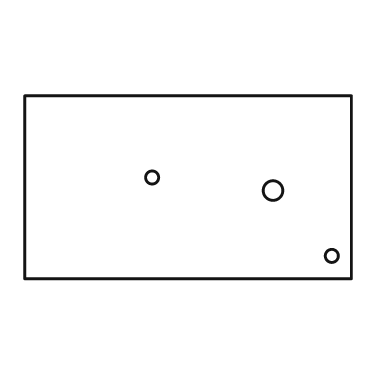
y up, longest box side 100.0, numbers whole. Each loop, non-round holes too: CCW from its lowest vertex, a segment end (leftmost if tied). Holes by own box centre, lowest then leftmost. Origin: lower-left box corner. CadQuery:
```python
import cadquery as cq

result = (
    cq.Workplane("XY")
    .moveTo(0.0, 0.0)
    .lineTo(100.0, 0.0)
    .lineTo(100.0, 56.0)
    .lineTo(0.0, 56.0)
    .close()
    .moveTo(94.0, 7.0)
    .circle(2.0)
    .moveTo(76.0, 27.0)
    .circle(3.0)
    .moveTo(39.0, 31.0)
    .circle(2.0)
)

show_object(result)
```